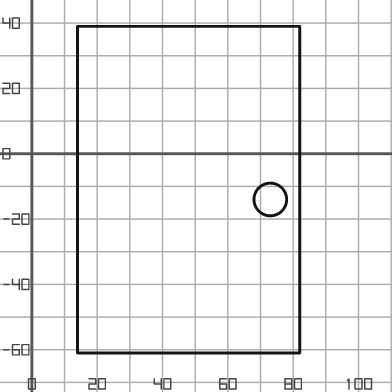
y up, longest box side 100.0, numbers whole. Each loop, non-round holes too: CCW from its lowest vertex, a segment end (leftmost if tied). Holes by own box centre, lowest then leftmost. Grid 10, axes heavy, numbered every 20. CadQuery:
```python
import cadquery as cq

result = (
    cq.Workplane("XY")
    .moveTo(14.0, -61.0)
    .lineTo(82.0, -61.0)
    .lineTo(82.0, 39.0)
    .lineTo(14.0, 39.0)
    .close()
    .moveTo(73.0, -14.0)
    .circle(5.0)
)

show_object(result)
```